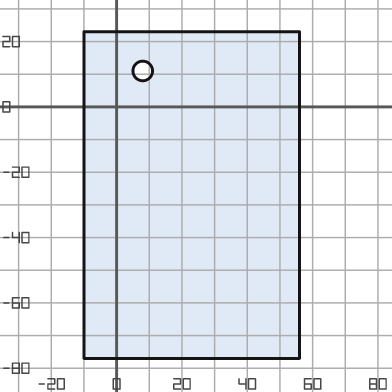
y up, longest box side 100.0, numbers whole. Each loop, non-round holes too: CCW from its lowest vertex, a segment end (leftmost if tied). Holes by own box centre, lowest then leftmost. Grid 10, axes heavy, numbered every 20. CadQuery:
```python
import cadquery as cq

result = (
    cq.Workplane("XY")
    .moveTo(-10.0, -77.0)
    .lineTo(56.0, -77.0)
    .lineTo(56.0, 23.0)
    .lineTo(-10.0, 23.0)
    .close()
    .moveTo(8.0, 11.0)
    .circle(3.0)
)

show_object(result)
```